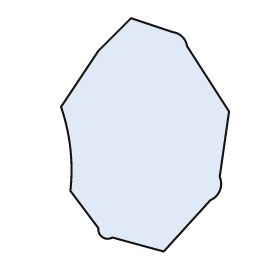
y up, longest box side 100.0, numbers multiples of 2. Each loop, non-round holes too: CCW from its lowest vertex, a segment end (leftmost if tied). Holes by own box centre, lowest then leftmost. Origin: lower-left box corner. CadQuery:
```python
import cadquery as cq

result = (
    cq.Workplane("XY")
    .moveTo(44.0, 0.0)
    .lineTo(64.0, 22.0)
    .threePointArc((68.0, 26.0), (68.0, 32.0))
    .lineTo(72.0, 60.0)
    .lineTo(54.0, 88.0)
    .threePointArc((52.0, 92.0), (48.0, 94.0))
    .lineTo(30.0, 100.0)
    .lineTo(16.0, 86.0)
    .lineTo(0.0, 62.0)
    .threePointArc((4.0, 44.0), (4.0, 26.0))
    .lineTo(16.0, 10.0)
    .threePointArc((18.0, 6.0), (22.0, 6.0))
    .close()
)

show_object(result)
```